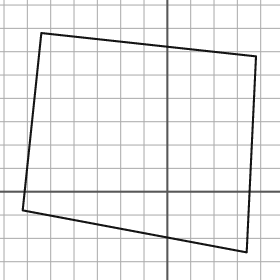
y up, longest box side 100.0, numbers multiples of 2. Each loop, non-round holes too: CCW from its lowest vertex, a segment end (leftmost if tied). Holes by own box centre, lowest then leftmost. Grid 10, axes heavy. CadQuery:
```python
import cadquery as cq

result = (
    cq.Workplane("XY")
    .moveTo(34.0, -26.0)
    .lineTo(38.0, 58.0)
    .lineTo(-54.0, 68.0)
    .lineTo(-62.0, -8.0)
    .close()
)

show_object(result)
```